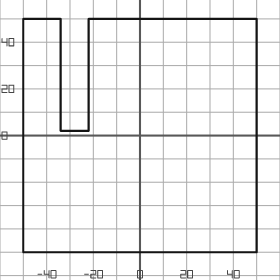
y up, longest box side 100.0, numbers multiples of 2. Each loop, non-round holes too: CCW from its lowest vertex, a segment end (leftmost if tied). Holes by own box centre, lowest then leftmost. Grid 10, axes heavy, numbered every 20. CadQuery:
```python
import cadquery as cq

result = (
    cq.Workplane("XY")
    .moveTo(-50.0, -50.0)
    .lineTo(50.0, -50.0)
    .lineTo(50.0, 50.0)
    .lineTo(-22.0, 50.0)
    .lineTo(-22.0, 2.0)
    .lineTo(-34.0, 2.0)
    .lineTo(-34.0, 50.0)
    .lineTo(-50.0, 50.0)
    .close()
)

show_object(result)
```